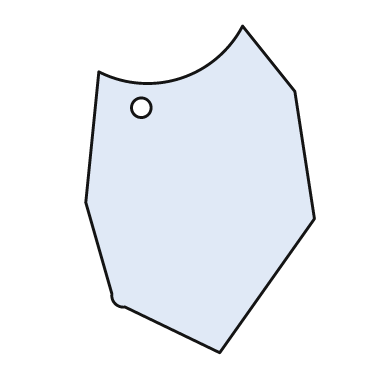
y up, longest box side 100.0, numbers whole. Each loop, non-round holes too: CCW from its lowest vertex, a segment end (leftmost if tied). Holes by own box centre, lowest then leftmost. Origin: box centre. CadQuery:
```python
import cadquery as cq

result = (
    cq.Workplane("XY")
    .moveTo(6.0, -50.0)
    .lineTo(35.0, -9.0)
    .lineTo(29.0, 30.0)
    .lineTo(13.0, 50.0)
    .threePointArc((-6.0, 34.0), (-31.0, 36.0))
    .lineTo(-35.0, -4.0)
    .lineTo(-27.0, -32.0)
    .threePointArc((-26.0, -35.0), (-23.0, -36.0))
    .close()
    .moveTo(-18.0, 25.0)
    .circle(3.0)
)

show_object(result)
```